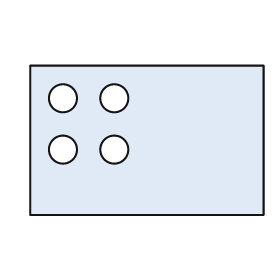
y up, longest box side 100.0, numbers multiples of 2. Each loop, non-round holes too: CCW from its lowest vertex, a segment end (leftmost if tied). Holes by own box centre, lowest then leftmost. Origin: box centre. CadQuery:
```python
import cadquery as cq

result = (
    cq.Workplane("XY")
    .moveTo(-50.0, -32.0)
    .lineTo(50.0, -32.0)
    .lineTo(50.0, 32.0)
    .lineTo(-50.0, 32.0)
    .close()
    .moveTo(-36.0, -4.0)
    .circle(6.0)
    .moveTo(-14.0, -4.0)
    .circle(6.0)
    .moveTo(-36.0, 18.0)
    .circle(6.0)
    .moveTo(-14.0, 18.0)
    .circle(6.0)
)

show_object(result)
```